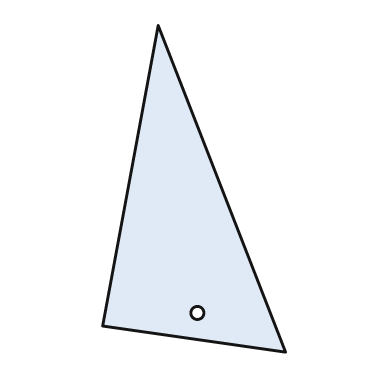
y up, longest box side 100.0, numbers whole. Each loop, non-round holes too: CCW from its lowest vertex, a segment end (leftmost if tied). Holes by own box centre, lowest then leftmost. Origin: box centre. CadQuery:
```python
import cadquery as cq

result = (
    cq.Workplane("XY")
    .moveTo(28.0, -50.0)
    .lineTo(-11.0, 50.0)
    .lineTo(-28.0, -42.0)
    .close()
    .moveTo(1.0, -38.0)
    .circle(2.0)
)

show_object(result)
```